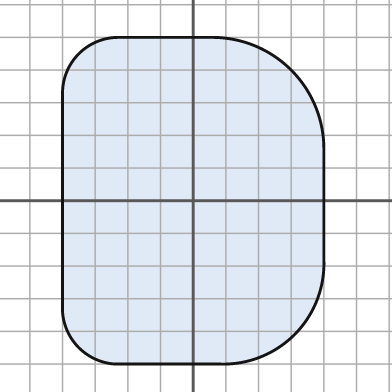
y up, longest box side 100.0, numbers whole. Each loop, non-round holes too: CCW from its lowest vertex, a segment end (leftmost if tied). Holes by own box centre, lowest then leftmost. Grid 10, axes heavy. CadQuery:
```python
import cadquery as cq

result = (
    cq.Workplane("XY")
    .moveTo(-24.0, -50.0)
    .lineTo(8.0, -50.0)
    .threePointArc((31.0, -41.0), (40.0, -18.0))
    .lineTo(40.0, 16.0)
    .threePointArc((30.0, 40.0), (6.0, 50.0))
    .lineTo(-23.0, 50.0)
    .threePointArc((-35.0, 45.0), (-40.0, 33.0))
    .lineTo(-40.0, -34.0)
    .threePointArc((-35.0, -45.0), (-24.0, -50.0))
    .close()
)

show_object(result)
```